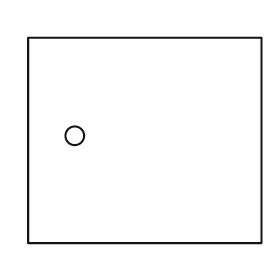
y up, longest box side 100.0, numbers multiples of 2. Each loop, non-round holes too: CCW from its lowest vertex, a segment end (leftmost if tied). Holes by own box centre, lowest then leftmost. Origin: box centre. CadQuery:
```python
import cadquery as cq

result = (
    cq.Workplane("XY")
    .moveTo(-50.0, -44.0)
    .lineTo(50.0, -44.0)
    .lineTo(50.0, 44.0)
    .lineTo(-50.0, 44.0)
    .close()
    .moveTo(-30.0, 2.0)
    .circle(4.0)
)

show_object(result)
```